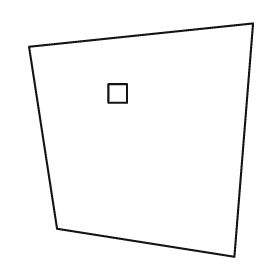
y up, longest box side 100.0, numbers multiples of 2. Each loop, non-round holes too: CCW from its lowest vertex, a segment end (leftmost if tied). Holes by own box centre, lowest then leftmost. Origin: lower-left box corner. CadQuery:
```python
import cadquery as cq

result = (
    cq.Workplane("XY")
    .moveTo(88.0, 0.0)
    .lineTo(96.0, 100.0)
    .lineTo(0.0, 90.0)
    .lineTo(12.0, 12.0)
    .close()
    .moveTo(34.0, 66.0)
    .lineTo(42.0, 66.0)
    .lineTo(42.0, 74.0)
    .lineTo(34.0, 74.0)
    .close()
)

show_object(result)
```